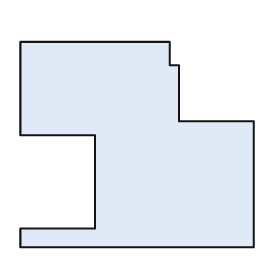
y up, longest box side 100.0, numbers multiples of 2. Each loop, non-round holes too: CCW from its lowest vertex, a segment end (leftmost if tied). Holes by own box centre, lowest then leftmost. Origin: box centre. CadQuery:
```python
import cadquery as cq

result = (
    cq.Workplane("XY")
    .moveTo(-50.0, -44.0)
    .lineTo(50.0, -44.0)
    .lineTo(50.0, 10.0)
    .lineTo(18.0, 10.0)
    .lineTo(18.0, 34.0)
    .lineTo(14.0, 34.0)
    .lineTo(14.0, 44.0)
    .lineTo(-50.0, 44.0)
    .lineTo(-50.0, 4.0)
    .lineTo(-18.0, 4.0)
    .lineTo(-18.0, -36.0)
    .lineTo(-50.0, -36.0)
    .close()
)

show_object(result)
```